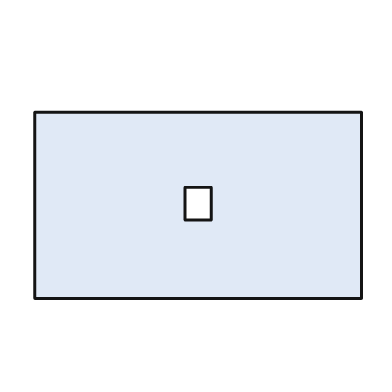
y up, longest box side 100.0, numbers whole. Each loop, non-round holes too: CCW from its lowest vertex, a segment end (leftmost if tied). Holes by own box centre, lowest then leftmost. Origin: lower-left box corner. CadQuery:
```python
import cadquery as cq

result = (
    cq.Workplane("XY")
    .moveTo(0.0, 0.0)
    .lineTo(100.0, 0.0)
    .lineTo(100.0, 57.0)
    .lineTo(0.0, 57.0)
    .close()
    .moveTo(46.0, 24.0)
    .lineTo(54.0, 24.0)
    .lineTo(54.0, 34.0)
    .lineTo(46.0, 34.0)
    .close()
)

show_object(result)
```